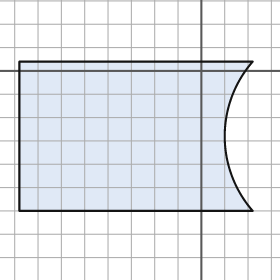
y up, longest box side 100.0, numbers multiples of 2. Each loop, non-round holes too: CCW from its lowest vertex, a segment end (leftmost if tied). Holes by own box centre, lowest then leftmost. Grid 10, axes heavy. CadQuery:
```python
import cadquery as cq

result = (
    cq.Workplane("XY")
    .moveTo(-78.0, -60.0)
    .lineTo(22.0, -60.0)
    .threePointArc((10.0, -28.0), (22.0, 4.0))
    .lineTo(-78.0, 4.0)
    .close()
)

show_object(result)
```